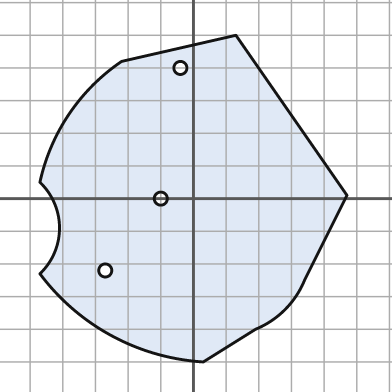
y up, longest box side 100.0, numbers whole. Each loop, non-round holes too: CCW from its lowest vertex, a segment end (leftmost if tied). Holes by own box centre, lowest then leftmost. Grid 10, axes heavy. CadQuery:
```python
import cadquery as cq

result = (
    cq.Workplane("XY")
    .moveTo(3.0, -50.0)
    .lineTo(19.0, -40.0)
    .threePointArc((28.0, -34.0), (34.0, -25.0))
    .lineTo(47.0, 1.0)
    .lineTo(13.0, 50.0)
    .lineTo(-22.0, 42.0)
    .threePointArc((-38.0, 26.0), (-47.0, 5.0))
    .threePointArc((-41.0, -9.0), (-47.0, -23.0))
    .threePointArc((-25.0, -42.0), (3.0, -50.0))
    .close()
    .moveTo(-27.0, -22.0)
    .circle(2.0)
    .moveTo(-10.0, 0.0)
    .circle(2.0)
    .moveTo(-4.0, 40.0)
    .circle(2.0)
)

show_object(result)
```